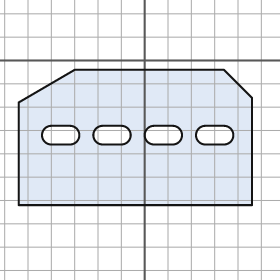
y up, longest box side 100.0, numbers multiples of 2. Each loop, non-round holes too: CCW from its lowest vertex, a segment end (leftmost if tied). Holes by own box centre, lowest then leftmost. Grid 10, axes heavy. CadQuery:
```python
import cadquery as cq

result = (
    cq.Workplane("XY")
    .moveTo(-54.0, -62.0)
    .lineTo(46.0, -62.0)
    .lineTo(46.0, -16.0)
    .lineTo(34.0, -4.0)
    .lineTo(-30.0, -4.0)
    .lineTo(-54.0, -18.0)
    .close()
    .moveTo(-40.0, -36.0)
    .lineTo(-32.0, -36.0)
    .threePointArc((-28.0, -32.0), (-32.0, -28.0))
    .lineTo(-40.0, -28.0)
    .threePointArc((-44.0, -32.0), (-40.0, -36.0))
    .close()
    .moveTo(-18.0, -36.0)
    .lineTo(-10.0, -36.0)
    .threePointArc((-6.0, -32.0), (-10.0, -28.0))
    .lineTo(-18.0, -28.0)
    .threePointArc((-22.0, -32.0), (-18.0, -36.0))
    .close()
    .moveTo(4.0, -36.0)
    .lineTo(12.0, -36.0)
    .threePointArc((16.0, -32.0), (12.0, -28.0))
    .lineTo(4.0, -28.0)
    .threePointArc((0.0, -32.0), (4.0, -36.0))
    .close()
    .moveTo(26.0, -36.0)
    .lineTo(34.0, -36.0)
    .threePointArc((38.0, -32.0), (34.0, -28.0))
    .lineTo(26.0, -28.0)
    .threePointArc((22.0, -32.0), (26.0, -36.0))
    .close()
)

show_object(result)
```